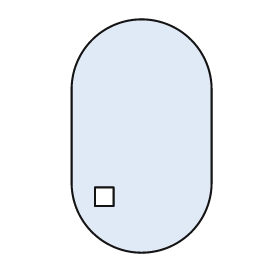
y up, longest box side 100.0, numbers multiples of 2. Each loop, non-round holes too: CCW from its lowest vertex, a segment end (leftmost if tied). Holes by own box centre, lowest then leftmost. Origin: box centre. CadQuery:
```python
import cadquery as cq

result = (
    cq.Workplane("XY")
    .moveTo(-30.0, -20.0)
    .threePointArc((0.0, -50.0), (30.0, -20.0))
    .lineTo(30.0, 20.0)
    .threePointArc((0.0, 50.0), (-30.0, 20.0))
    .close()
    .moveTo(-20.0, -30.0)
    .lineTo(-12.0, -30.0)
    .lineTo(-12.0, -22.0)
    .lineTo(-20.0, -22.0)
    .close()
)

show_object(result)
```